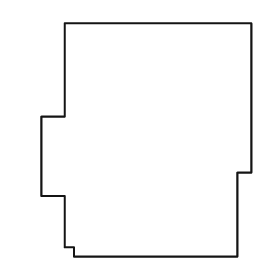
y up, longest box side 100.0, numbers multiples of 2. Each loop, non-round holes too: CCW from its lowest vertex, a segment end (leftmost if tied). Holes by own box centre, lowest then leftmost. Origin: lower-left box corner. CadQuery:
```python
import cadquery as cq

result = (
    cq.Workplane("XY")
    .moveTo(14.0, 0.0)
    .lineTo(84.0, 0.0)
    .lineTo(84.0, 36.0)
    .lineTo(90.0, 36.0)
    .lineTo(90.0, 100.0)
    .lineTo(10.0, 100.0)
    .lineTo(10.0, 60.0)
    .lineTo(0.0, 60.0)
    .lineTo(0.0, 26.0)
    .lineTo(10.0, 26.0)
    .lineTo(10.0, 4.0)
    .lineTo(14.0, 4.0)
    .close()
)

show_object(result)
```